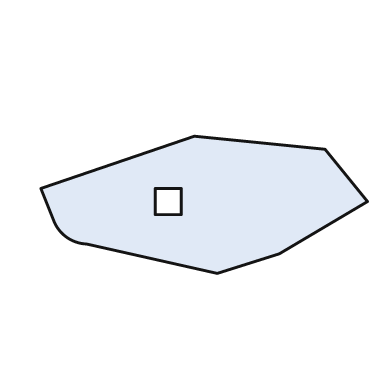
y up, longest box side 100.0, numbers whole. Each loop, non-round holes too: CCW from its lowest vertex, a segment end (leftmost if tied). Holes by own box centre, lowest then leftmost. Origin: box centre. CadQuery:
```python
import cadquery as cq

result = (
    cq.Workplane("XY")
    .moveTo(4.0, -21.0)
    .lineTo(23.0, -15.0)
    .lineTo(50.0, 1.0)
    .lineTo(37.0, 17.0)
    .lineTo(-3.0, 21.0)
    .lineTo(-50.0, 5.0)
    .lineTo(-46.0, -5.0)
    .threePointArc((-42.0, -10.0), (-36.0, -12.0))
    .close()
    .moveTo(-15.0, -3.0)
    .lineTo(-7.0, -3.0)
    .lineTo(-7.0, 5.0)
    .lineTo(-15.0, 5.0)
    .close()
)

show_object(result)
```